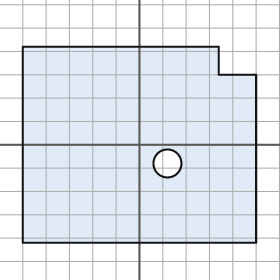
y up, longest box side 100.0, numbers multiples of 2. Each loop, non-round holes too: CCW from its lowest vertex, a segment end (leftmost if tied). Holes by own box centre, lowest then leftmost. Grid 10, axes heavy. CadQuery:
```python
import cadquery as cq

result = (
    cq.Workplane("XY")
    .moveTo(-50.0, -42.0)
    .lineTo(50.0, -42.0)
    .lineTo(50.0, 30.0)
    .lineTo(34.0, 30.0)
    .lineTo(34.0, 42.0)
    .lineTo(-50.0, 42.0)
    .close()
    .moveTo(12.0, -8.0)
    .circle(6.0)
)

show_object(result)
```